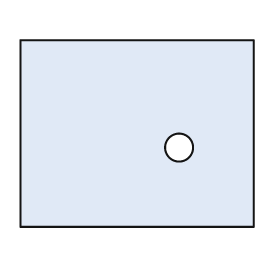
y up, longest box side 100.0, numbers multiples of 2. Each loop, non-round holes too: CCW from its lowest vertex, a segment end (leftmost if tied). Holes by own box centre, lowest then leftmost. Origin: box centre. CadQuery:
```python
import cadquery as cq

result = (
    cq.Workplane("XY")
    .moveTo(-50.0, -40.0)
    .lineTo(50.0, -40.0)
    .lineTo(50.0, 40.0)
    .lineTo(-50.0, 40.0)
    .close()
    .moveTo(18.0, -6.0)
    .circle(6.0)
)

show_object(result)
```